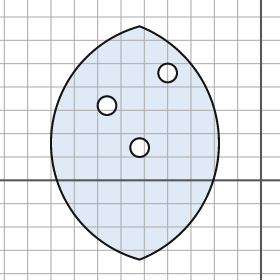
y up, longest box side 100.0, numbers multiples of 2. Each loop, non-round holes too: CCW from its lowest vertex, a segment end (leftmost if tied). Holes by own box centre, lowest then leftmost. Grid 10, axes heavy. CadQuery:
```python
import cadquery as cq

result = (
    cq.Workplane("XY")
    .moveTo(-52.0, -34.0)
    .threePointArc((-18.0, 16.0), (-52.0, 66.0))
    .threePointArc((-90.0, 16.0), (-52.0, -34.0))
    .close()
    .moveTo(-52.0, 14.0)
    .circle(4.0)
    .moveTo(-66.0, 32.0)
    .circle(4.0)
    .moveTo(-40.0, 46.0)
    .circle(4.0)
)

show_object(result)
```